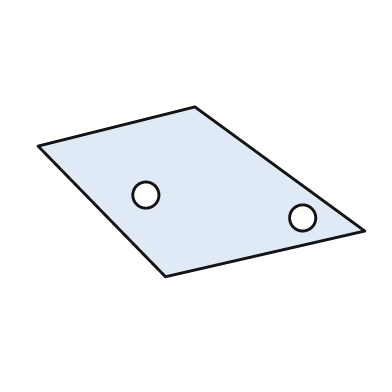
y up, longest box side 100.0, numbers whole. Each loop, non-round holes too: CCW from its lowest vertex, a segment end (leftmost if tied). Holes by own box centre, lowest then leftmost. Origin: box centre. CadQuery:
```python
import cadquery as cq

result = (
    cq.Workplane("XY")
    .moveTo(-11.0, -26.0)
    .lineTo(50.0, -12.0)
    .lineTo(-2.0, 26.0)
    .lineTo(-50.0, 14.0)
    .close()
    .moveTo(31.0, -8.0)
    .circle(4.0)
    .moveTo(-17.0, -1.0)
    .circle(4.0)
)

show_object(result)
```